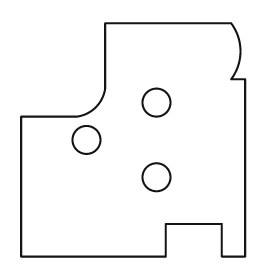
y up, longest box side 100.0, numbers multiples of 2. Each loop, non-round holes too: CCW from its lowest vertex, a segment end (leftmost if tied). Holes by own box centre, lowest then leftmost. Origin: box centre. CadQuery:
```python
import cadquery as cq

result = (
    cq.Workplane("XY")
    .moveTo(-48.0, -50.0)
    .lineTo(14.0, -50.0)
    .lineTo(14.0, -36.0)
    .lineTo(38.0, -36.0)
    .lineTo(38.0, -50.0)
    .lineTo(48.0, -50.0)
    .lineTo(48.0, 26.0)
    .lineTo(42.0, 26.0)
    .threePointArc((46.0, 38.0), (42.0, 50.0))
    .lineTo(-12.0, 50.0)
    .lineTo(-12.0, 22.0)
    .threePointArc((-16.0, 14.0), (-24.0, 10.0))
    .lineTo(-48.0, 10.0)
    .close()
    .moveTo(10.0, -16.0)
    .circle(6.0)
    .moveTo(-20.0, 0.0)
    .circle(6.0)
    .moveTo(10.0, 16.0)
    .circle(6.0)
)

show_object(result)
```